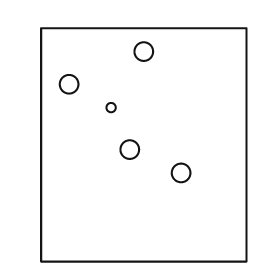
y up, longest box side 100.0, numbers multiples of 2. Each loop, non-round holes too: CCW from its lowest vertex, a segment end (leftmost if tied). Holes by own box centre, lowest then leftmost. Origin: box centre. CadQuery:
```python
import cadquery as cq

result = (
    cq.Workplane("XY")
    .moveTo(-44.0, -50.0)
    .lineTo(44.0, -50.0)
    .lineTo(44.0, 50.0)
    .lineTo(-44.0, 50.0)
    .close()
    .moveTo(16.0, -12.0)
    .circle(4.0)
    .moveTo(-6.0, -2.0)
    .circle(4.0)
    .moveTo(-14.0, 16.0)
    .circle(2.0)
    .moveTo(-32.0, 26.0)
    .circle(4.0)
    .moveTo(0.0, 40.0)
    .circle(4.0)
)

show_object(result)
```